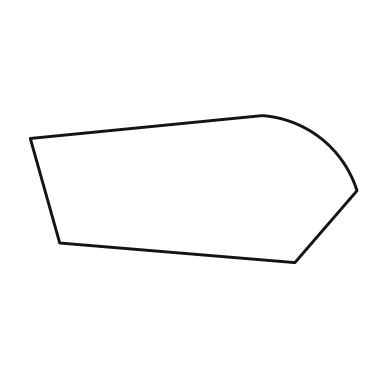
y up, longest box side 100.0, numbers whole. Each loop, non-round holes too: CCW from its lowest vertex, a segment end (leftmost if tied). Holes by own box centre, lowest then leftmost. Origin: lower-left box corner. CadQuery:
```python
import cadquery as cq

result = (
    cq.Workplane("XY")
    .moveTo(81.0, 0.0)
    .lineTo(100.0, 22.0)
    .threePointArc((89.0, 38.0), (71.0, 45.0))
    .lineTo(0.0, 38.0)
    .lineTo(9.0, 6.0)
    .close()
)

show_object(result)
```